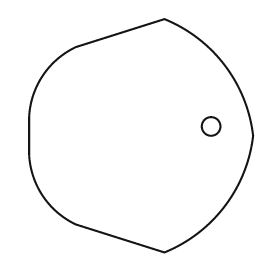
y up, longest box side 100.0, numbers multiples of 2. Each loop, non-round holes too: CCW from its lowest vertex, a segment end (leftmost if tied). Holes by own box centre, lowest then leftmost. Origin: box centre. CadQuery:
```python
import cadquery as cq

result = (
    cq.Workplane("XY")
    .moveTo(10.0, -50.0)
    .threePointArc((36.0, -30.0), (48.0, 0.0))
    .threePointArc((36.0, 30.0), (10.0, 50.0))
    .lineTo(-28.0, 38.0)
    .threePointArc((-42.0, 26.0), (-48.0, 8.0))
    .lineTo(-48.0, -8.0)
    .threePointArc((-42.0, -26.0), (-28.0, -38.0))
    .close()
    .moveTo(30.0, 4.0)
    .circle(4.0)
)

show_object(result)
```